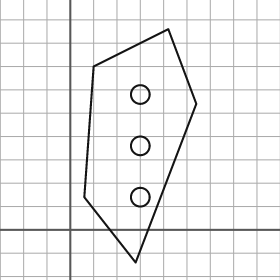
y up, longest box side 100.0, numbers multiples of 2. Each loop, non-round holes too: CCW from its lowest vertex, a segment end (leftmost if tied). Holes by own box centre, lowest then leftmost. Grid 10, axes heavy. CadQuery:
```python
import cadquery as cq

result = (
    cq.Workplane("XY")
    .moveTo(28.0, -14.0)
    .lineTo(54.0, 54.0)
    .lineTo(42.0, 86.0)
    .lineTo(10.0, 70.0)
    .lineTo(6.0, 14.0)
    .close()
    .moveTo(30.0, 14.0)
    .circle(4.0)
    .moveTo(30.0, 36.0)
    .circle(4.0)
    .moveTo(30.0, 58.0)
    .circle(4.0)
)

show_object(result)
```